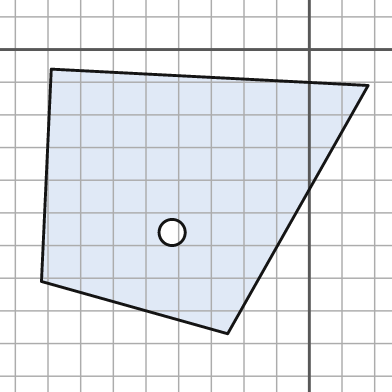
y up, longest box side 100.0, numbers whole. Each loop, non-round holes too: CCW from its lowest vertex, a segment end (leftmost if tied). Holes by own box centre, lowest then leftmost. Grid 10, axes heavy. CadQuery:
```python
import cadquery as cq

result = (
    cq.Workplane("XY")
    .moveTo(-25.0, -87.0)
    .lineTo(18.0, -11.0)
    .lineTo(-79.0, -6.0)
    .lineTo(-82.0, -71.0)
    .close()
    .moveTo(-42.0, -56.0)
    .circle(4.0)
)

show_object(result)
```